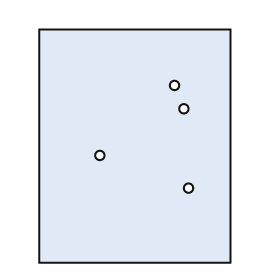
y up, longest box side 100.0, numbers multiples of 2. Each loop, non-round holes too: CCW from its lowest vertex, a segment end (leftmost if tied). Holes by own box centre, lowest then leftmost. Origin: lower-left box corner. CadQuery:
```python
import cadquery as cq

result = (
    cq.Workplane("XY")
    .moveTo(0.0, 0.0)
    .lineTo(82.0, 0.0)
    .lineTo(82.0, 100.0)
    .lineTo(0.0, 100.0)
    .close()
    .moveTo(64.0, 32.0)
    .circle(2.0)
    .moveTo(26.0, 46.0)
    .circle(2.0)
    .moveTo(62.0, 66.0)
    .circle(2.0)
    .moveTo(58.0, 76.0)
    .circle(2.0)
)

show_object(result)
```